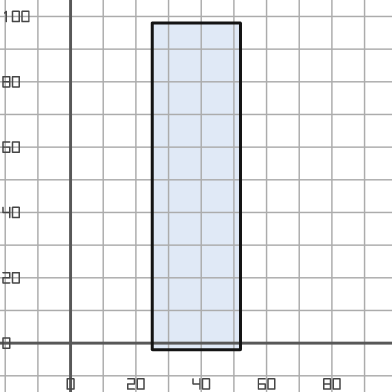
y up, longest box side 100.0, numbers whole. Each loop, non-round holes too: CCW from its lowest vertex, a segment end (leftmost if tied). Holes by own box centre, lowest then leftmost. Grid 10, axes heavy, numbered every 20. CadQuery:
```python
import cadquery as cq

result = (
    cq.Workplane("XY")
    .moveTo(25.0, -2.0)
    .lineTo(52.0, -2.0)
    .lineTo(52.0, 98.0)
    .lineTo(25.0, 98.0)
    .close()
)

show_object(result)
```